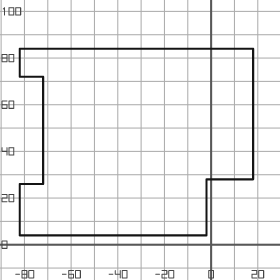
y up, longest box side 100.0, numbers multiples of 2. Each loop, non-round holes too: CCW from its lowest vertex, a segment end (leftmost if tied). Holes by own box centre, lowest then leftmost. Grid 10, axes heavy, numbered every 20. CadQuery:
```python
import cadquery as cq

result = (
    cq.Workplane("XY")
    .moveTo(-82.0, 4.0)
    .lineTo(-2.0, 4.0)
    .lineTo(-2.0, 28.0)
    .lineTo(18.0, 28.0)
    .lineTo(18.0, 84.0)
    .lineTo(-82.0, 84.0)
    .lineTo(-82.0, 72.0)
    .lineTo(-72.0, 72.0)
    .lineTo(-72.0, 26.0)
    .lineTo(-82.0, 26.0)
    .close()
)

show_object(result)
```